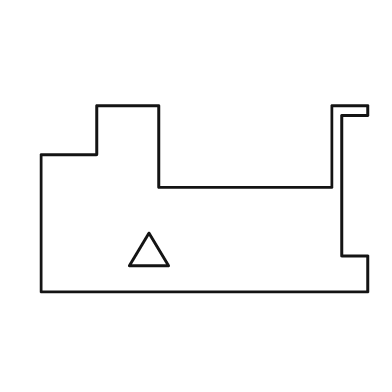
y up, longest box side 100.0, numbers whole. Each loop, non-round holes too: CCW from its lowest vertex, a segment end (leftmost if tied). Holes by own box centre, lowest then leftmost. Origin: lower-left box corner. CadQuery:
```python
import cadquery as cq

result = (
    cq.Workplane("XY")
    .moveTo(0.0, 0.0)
    .lineTo(100.0, 0.0)
    .lineTo(100.0, 11.0)
    .lineTo(92.0, 11.0)
    .lineTo(92.0, 54.0)
    .lineTo(100.0, 54.0)
    .lineTo(100.0, 57.0)
    .lineTo(89.0, 57.0)
    .lineTo(89.0, 32.0)
    .lineTo(36.0, 32.0)
    .lineTo(36.0, 57.0)
    .lineTo(17.0, 57.0)
    .lineTo(17.0, 42.0)
    .lineTo(0.0, 42.0)
    .close()
    .moveTo(27.0, 8.0)
    .lineTo(39.0, 8.0)
    .lineTo(33.0, 18.0)
    .close()
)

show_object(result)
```